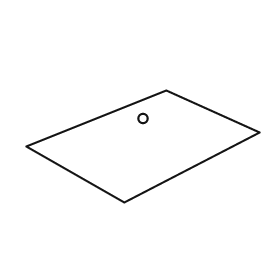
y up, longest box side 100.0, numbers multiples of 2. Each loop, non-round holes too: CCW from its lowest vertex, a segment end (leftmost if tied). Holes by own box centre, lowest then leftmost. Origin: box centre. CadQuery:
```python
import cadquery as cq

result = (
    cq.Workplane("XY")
    .moveTo(-8.0, -24.0)
    .lineTo(50.0, 6.0)
    .lineTo(10.0, 24.0)
    .lineTo(-50.0, 0.0)
    .close()
    .moveTo(0.0, 12.0)
    .circle(2.0)
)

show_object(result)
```